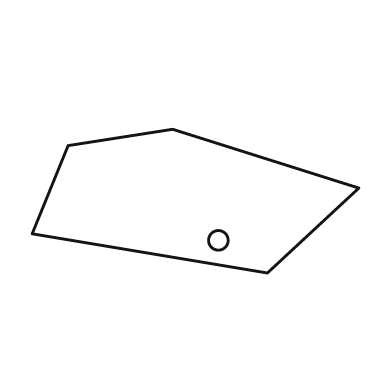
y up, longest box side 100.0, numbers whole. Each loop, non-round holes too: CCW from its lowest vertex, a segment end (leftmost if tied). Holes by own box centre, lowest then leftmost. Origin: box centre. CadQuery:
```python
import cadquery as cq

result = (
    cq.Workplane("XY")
    .moveTo(22.0, -22.0)
    .lineTo(50.0, 4.0)
    .lineTo(-7.0, 22.0)
    .lineTo(-39.0, 17.0)
    .lineTo(-50.0, -10.0)
    .close()
    .moveTo(7.0, -12.0)
    .circle(3.0)
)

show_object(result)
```